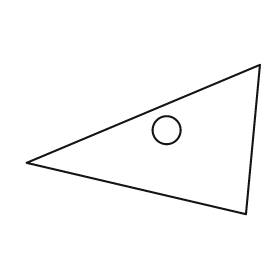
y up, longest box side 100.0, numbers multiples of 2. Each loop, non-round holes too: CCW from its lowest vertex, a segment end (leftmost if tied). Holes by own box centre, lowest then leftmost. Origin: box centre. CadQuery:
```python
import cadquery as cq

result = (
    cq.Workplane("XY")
    .moveTo(44.0, -32.0)
    .lineTo(50.0, 32.0)
    .lineTo(-50.0, -10.0)
    .close()
    .moveTo(10.0, 4.0)
    .circle(6.0)
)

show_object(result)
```